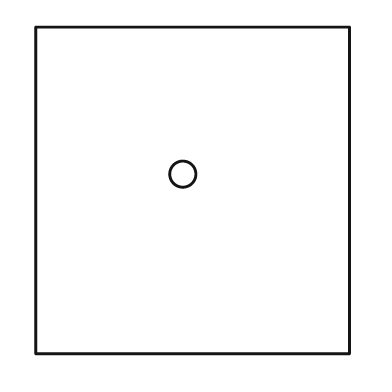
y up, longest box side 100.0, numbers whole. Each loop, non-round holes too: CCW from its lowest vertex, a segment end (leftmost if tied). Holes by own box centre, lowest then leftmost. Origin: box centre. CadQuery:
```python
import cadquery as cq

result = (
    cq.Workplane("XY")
    .moveTo(-48.0, -50.0)
    .lineTo(48.0, -50.0)
    .lineTo(48.0, 50.0)
    .lineTo(-48.0, 50.0)
    .close()
    .moveTo(-3.0, 5.0)
    .circle(4.0)
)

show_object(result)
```